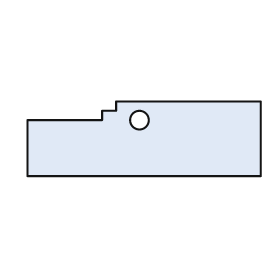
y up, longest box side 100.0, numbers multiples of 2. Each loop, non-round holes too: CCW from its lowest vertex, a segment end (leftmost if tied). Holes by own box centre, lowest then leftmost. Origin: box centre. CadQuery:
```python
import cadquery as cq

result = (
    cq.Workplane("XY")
    .moveTo(-50.0, -16.0)
    .lineTo(50.0, -16.0)
    .lineTo(50.0, 16.0)
    .lineTo(-12.0, 16.0)
    .lineTo(-12.0, 12.0)
    .lineTo(-18.0, 12.0)
    .lineTo(-18.0, 8.0)
    .lineTo(-50.0, 8.0)
    .close()
    .moveTo(-2.0, 8.0)
    .circle(4.0)
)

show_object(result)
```